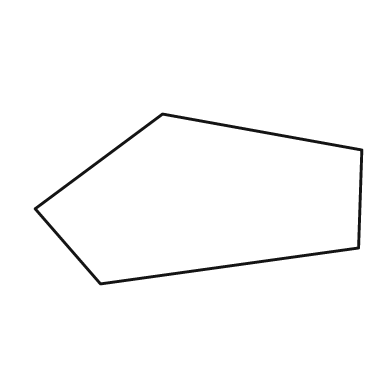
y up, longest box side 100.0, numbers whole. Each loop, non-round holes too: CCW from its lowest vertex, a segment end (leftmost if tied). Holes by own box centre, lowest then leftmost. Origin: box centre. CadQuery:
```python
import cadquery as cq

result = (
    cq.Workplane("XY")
    .moveTo(-30.0, -26.0)
    .lineTo(49.0, -15.0)
    .lineTo(50.0, 15.0)
    .lineTo(-11.0, 26.0)
    .lineTo(-50.0, -3.0)
    .close()
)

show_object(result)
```